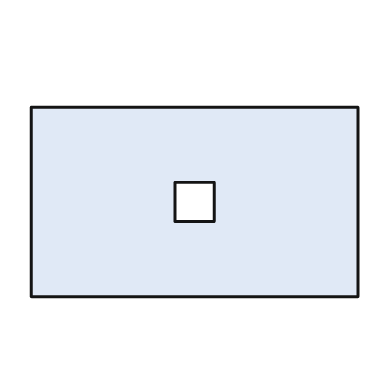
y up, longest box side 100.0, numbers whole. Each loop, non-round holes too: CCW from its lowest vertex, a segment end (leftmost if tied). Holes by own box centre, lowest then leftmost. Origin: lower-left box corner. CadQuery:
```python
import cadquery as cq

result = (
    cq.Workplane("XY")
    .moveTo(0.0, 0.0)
    .lineTo(100.0, 0.0)
    .lineTo(100.0, 58.0)
    .lineTo(0.0, 58.0)
    .close()
    .moveTo(44.0, 23.0)
    .lineTo(56.0, 23.0)
    .lineTo(56.0, 35.0)
    .lineTo(44.0, 35.0)
    .close()
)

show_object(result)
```